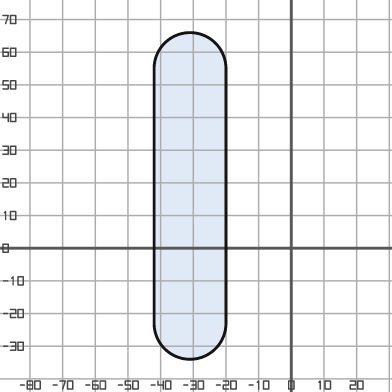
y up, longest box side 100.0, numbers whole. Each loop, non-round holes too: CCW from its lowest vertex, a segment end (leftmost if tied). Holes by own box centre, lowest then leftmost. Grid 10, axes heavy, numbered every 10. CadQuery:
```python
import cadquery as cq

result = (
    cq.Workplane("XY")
    .moveTo(-42.0, -23.0)
    .threePointArc((-31.0, -34.0), (-20.0, -23.0))
    .lineTo(-20.0, 55.0)
    .threePointArc((-31.0, 66.0), (-42.0, 55.0))
    .close()
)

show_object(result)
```